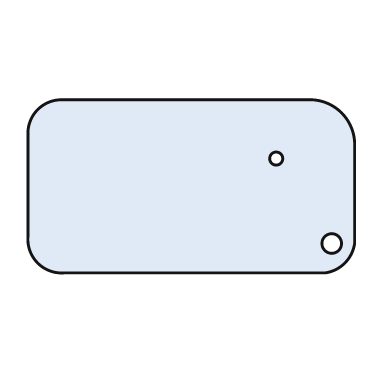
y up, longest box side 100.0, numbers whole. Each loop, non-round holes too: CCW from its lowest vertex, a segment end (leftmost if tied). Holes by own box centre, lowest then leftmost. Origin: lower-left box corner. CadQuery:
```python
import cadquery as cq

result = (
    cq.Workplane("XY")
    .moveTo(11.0, 0.0)
    .lineTo(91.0, 0.0)
    .threePointArc((97.0, 3.0), (100.0, 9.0))
    .lineTo(100.0, 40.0)
    .threePointArc((96.0, 49.0), (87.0, 53.0))
    .lineTo(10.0, 53.0)
    .threePointArc((3.0, 50.0), (0.0, 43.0))
    .lineTo(0.0, 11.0)
    .threePointArc((3.0, 3.0), (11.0, 0.0))
    .close()
    .moveTo(93.0, 9.0)
    .circle(3.0)
    .moveTo(76.0, 35.0)
    .circle(2.0)
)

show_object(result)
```